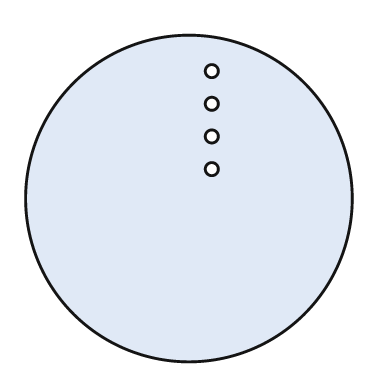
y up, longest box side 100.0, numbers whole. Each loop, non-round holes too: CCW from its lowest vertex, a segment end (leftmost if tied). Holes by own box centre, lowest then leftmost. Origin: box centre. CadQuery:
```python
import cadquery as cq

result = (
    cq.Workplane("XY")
    .moveTo(0.0, 0.0)
    .circle(50.0)
    .moveTo(7.0, 9.0)
    .circle(2.0)
    .moveTo(7.0, 19.0)
    .circle(2.0)
    .moveTo(7.0, 29.0)
    .circle(2.0)
    .moveTo(7.0, 39.0)
    .circle(2.0)
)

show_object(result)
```